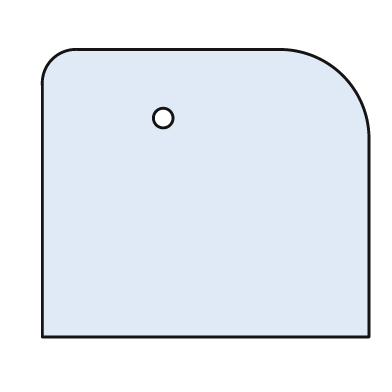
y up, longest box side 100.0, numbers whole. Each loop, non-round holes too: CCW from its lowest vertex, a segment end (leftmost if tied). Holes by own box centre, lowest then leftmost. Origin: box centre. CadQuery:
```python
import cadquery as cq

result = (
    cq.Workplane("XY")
    .moveTo(-50.0, -44.0)
    .lineTo(50.0, -44.0)
    .lineTo(50.0, 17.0)
    .threePointArc((42.0, 36.0), (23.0, 44.0))
    .lineTo(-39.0, 44.0)
    .threePointArc((-47.0, 41.0), (-50.0, 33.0))
    .close()
    .moveTo(-13.0, 23.0)
    .circle(3.0)
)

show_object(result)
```